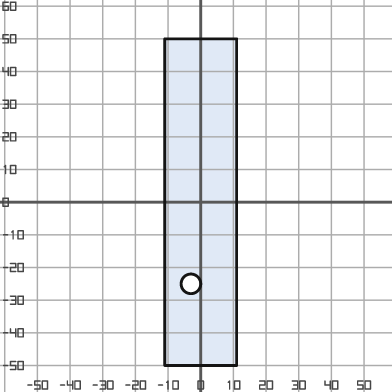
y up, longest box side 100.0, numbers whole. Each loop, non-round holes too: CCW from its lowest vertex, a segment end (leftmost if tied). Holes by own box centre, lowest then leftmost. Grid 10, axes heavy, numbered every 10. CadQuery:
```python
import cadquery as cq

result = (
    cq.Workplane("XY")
    .moveTo(-11.0, -50.0)
    .lineTo(11.0, -50.0)
    .lineTo(11.0, 50.0)
    .lineTo(-11.0, 50.0)
    .close()
    .moveTo(-3.0, -25.0)
    .circle(3.0)
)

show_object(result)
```